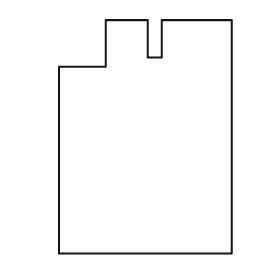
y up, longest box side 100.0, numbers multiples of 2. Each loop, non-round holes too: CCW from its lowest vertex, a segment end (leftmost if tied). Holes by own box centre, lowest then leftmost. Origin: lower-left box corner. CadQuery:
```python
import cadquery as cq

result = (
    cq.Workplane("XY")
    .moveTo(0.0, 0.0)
    .lineTo(74.0, 0.0)
    .lineTo(74.0, 100.0)
    .lineTo(44.0, 100.0)
    .lineTo(44.0, 84.0)
    .lineTo(38.0, 84.0)
    .lineTo(38.0, 100.0)
    .lineTo(20.0, 100.0)
    .lineTo(20.0, 80.0)
    .lineTo(0.0, 80.0)
    .close()
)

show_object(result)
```